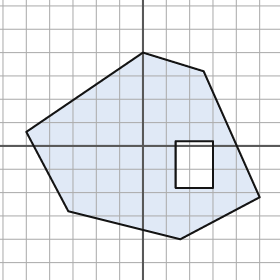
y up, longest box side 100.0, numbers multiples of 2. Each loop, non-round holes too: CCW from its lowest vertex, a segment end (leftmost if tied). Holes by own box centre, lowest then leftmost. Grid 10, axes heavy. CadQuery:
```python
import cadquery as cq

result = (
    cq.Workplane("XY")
    .moveTo(16.0, -40.0)
    .lineTo(50.0, -22.0)
    .lineTo(26.0, 32.0)
    .lineTo(0.0, 40.0)
    .lineTo(-50.0, 6.0)
    .lineTo(-32.0, -28.0)
    .close()
    .moveTo(14.0, -18.0)
    .lineTo(30.0, -18.0)
    .lineTo(30.0, 2.0)
    .lineTo(14.0, 2.0)
    .close()
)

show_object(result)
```